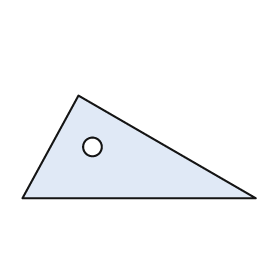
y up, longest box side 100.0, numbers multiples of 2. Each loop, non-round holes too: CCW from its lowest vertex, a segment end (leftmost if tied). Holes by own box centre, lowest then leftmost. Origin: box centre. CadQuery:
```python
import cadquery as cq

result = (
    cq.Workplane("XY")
    .moveTo(-50.0, -22.0)
    .lineTo(50.0, -22.0)
    .lineTo(-26.0, 22.0)
    .close()
    .moveTo(-20.0, 0.0)
    .circle(4.0)
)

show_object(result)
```